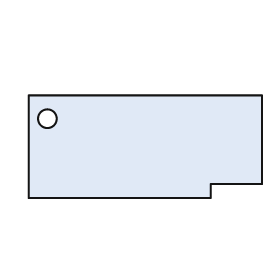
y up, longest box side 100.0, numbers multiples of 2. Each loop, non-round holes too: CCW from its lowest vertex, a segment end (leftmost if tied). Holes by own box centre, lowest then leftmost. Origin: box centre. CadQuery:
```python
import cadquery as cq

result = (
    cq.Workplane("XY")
    .moveTo(-50.0, -22.0)
    .lineTo(28.0, -22.0)
    .lineTo(28.0, -16.0)
    .lineTo(50.0, -16.0)
    .lineTo(50.0, 22.0)
    .lineTo(-50.0, 22.0)
    .close()
    .moveTo(-42.0, 12.0)
    .circle(4.0)
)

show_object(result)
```